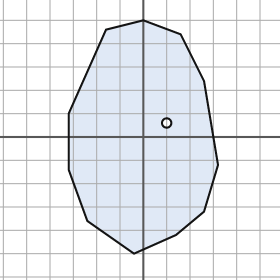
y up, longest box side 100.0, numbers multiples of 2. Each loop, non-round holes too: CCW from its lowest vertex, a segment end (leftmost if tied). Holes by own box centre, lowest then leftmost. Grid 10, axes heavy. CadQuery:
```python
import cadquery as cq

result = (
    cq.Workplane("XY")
    .moveTo(-4.0, -50.0)
    .lineTo(14.0, -42.0)
    .lineTo(26.0, -32.0)
    .lineTo(32.0, -12.0)
    .lineTo(26.0, 24.0)
    .lineTo(16.0, 44.0)
    .lineTo(0.0, 50.0)
    .lineTo(-16.0, 46.0)
    .lineTo(-32.0, 10.0)
    .lineTo(-32.0, -14.0)
    .lineTo(-24.0, -36.0)
    .close()
    .moveTo(10.0, 6.0)
    .circle(2.0)
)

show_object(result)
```